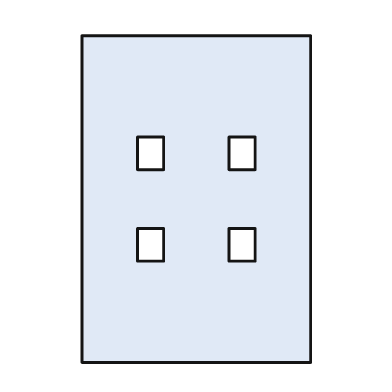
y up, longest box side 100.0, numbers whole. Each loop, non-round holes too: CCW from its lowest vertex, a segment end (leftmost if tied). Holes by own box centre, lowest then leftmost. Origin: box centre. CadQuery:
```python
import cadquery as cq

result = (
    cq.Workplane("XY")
    .moveTo(-35.0, -50.0)
    .lineTo(35.0, -50.0)
    .lineTo(35.0, 50.0)
    .lineTo(-35.0, 50.0)
    .close()
    .moveTo(-18.0, -19.0)
    .lineTo(-10.0, -19.0)
    .lineTo(-10.0, -9.0)
    .lineTo(-18.0, -9.0)
    .close()
    .moveTo(10.0, -19.0)
    .lineTo(18.0, -19.0)
    .lineTo(18.0, -9.0)
    .lineTo(10.0, -9.0)
    .close()
    .moveTo(-18.0, 9.0)
    .lineTo(-10.0, 9.0)
    .lineTo(-10.0, 19.0)
    .lineTo(-18.0, 19.0)
    .close()
    .moveTo(10.0, 9.0)
    .lineTo(18.0, 9.0)
    .lineTo(18.0, 19.0)
    .lineTo(10.0, 19.0)
    .close()
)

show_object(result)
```